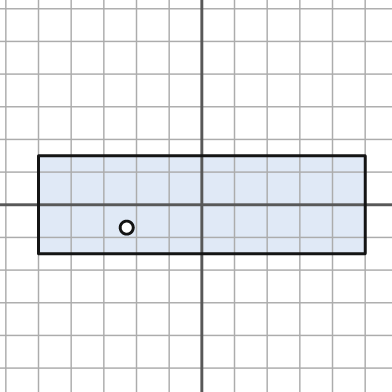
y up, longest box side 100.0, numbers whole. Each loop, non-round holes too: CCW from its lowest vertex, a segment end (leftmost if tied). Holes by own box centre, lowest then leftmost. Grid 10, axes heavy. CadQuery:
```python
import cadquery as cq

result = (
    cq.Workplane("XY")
    .moveTo(-50.0, -15.0)
    .lineTo(50.0, -15.0)
    .lineTo(50.0, 15.0)
    .lineTo(-50.0, 15.0)
    .close()
    .moveTo(-23.0, -7.0)
    .circle(2.0)
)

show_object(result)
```